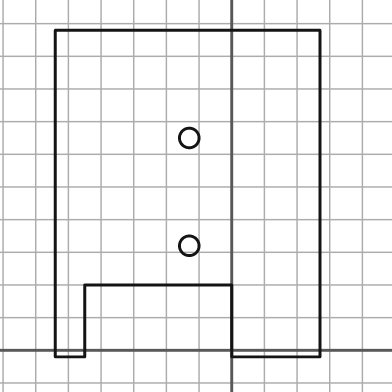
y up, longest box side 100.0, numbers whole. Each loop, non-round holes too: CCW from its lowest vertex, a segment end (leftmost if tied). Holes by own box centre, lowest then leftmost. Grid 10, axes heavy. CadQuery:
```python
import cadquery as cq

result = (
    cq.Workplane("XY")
    .moveTo(-54.0, -2.0)
    .lineTo(-45.0, -2.0)
    .lineTo(-45.0, 20.0)
    .lineTo(0.0, 20.0)
    .lineTo(0.0, -2.0)
    .lineTo(27.0, -2.0)
    .lineTo(27.0, 98.0)
    .lineTo(-54.0, 98.0)
    .close()
    .moveTo(-13.0, 32.0)
    .circle(3.0)
    .moveTo(-13.0, 65.0)
    .circle(3.0)
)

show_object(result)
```